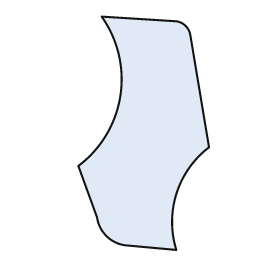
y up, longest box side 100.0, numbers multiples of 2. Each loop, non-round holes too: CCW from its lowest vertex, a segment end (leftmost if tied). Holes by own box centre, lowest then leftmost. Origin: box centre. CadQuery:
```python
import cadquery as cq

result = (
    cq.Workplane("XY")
    .moveTo(14.0, -50.0)
    .threePointArc((14.0, -26.0), (28.0, -6.0))
    .lineTo(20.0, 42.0)
    .threePointArc((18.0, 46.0), (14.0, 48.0))
    .lineTo(-18.0, 50.0)
    .threePointArc((-10.0, 16.0), (-28.0, -14.0))
    .lineTo(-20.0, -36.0)
    .threePointArc((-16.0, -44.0), (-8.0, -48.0))
    .close()
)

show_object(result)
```